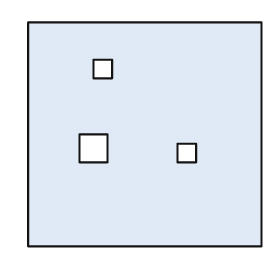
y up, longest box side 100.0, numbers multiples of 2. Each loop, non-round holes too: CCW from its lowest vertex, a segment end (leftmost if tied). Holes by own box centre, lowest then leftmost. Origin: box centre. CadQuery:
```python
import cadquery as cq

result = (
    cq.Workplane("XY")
    .moveTo(-50.0, -48.0)
    .lineTo(50.0, -48.0)
    .lineTo(50.0, 48.0)
    .lineTo(-50.0, 48.0)
    .close()
    .moveTo(14.0, -12.0)
    .lineTo(22.0, -12.0)
    .lineTo(22.0, -4.0)
    .lineTo(14.0, -4.0)
    .close()
    .moveTo(-28.0, -12.0)
    .lineTo(-16.0, -12.0)
    .lineTo(-16.0, 0.0)
    .lineTo(-28.0, 0.0)
    .close()
    .moveTo(-22.0, 24.0)
    .lineTo(-14.0, 24.0)
    .lineTo(-14.0, 32.0)
    .lineTo(-22.0, 32.0)
    .close()
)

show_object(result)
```